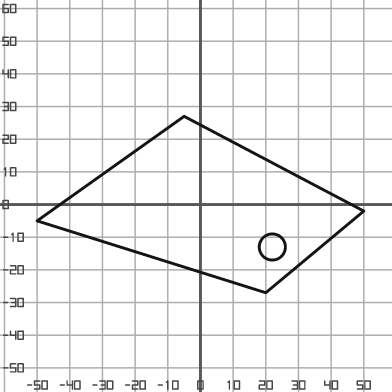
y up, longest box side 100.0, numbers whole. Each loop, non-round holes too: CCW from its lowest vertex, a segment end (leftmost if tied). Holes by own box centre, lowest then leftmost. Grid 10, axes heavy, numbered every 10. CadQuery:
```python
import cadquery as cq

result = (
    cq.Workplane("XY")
    .moveTo(20.0, -27.0)
    .lineTo(50.0, -2.0)
    .lineTo(-5.0, 27.0)
    .lineTo(-50.0, -5.0)
    .close()
    .moveTo(22.0, -13.0)
    .circle(4.0)
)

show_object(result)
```